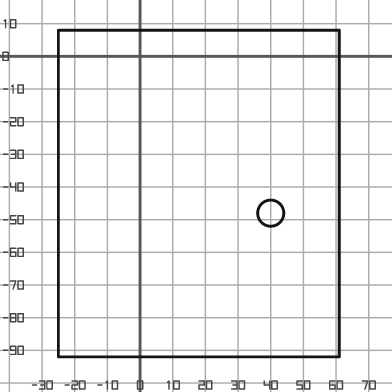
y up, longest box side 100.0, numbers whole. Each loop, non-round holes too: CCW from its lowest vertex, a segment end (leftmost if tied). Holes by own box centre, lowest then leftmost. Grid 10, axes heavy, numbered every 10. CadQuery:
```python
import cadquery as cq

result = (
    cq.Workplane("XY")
    .moveTo(-25.0, -92.0)
    .lineTo(61.0, -92.0)
    .lineTo(61.0, 8.0)
    .lineTo(-25.0, 8.0)
    .close()
    .moveTo(40.0, -48.0)
    .circle(4.0)
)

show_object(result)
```